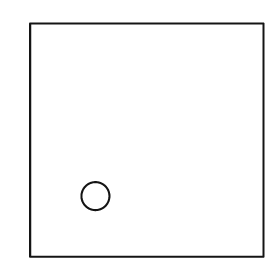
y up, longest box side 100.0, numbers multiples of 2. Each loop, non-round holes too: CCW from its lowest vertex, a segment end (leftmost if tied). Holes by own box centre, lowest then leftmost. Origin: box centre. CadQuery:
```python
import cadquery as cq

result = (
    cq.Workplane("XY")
    .moveTo(-50.0, -50.0)
    .lineTo(50.0, -50.0)
    .lineTo(50.0, 50.0)
    .lineTo(-50.0, 50.0)
    .close()
    .moveTo(-22.0, -24.0)
    .circle(6.0)
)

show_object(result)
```